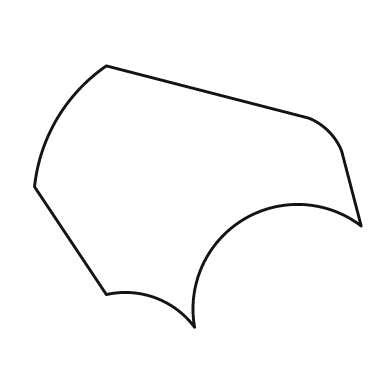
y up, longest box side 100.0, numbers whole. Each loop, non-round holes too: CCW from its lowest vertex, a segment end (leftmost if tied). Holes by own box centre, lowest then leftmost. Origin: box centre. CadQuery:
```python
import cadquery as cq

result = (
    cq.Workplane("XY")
    .moveTo(-1.0, -40.0)
    .threePointArc((14.0, -7.0), (50.0, -9.0))
    .lineTo(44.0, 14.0)
    .threePointArc((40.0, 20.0), (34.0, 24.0))
    .lineTo(-28.0, 40.0)
    .threePointArc((-43.0, 24.0), (-50.0, 3.0))
    .lineTo(-28.0, -30.0)
    .threePointArc((-13.0, -31.0), (-1.0, -40.0))
    .close()
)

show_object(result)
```